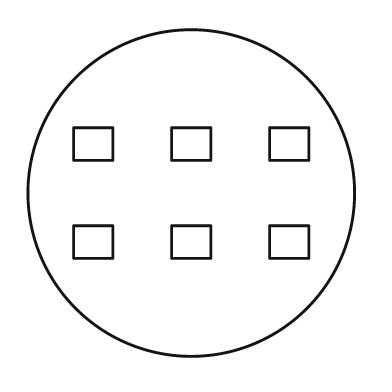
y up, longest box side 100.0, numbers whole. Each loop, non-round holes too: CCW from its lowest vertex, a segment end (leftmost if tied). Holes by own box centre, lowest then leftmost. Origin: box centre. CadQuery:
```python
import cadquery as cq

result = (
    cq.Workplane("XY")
    .moveTo(0.0, 0.0)
    .circle(50.0)
    .moveTo(-36.0, -20.0)
    .lineTo(-24.0, -20.0)
    .lineTo(-24.0, -10.0)
    .lineTo(-36.0, -10.0)
    .close()
    .moveTo(-6.0, -20.0)
    .lineTo(6.0, -20.0)
    .lineTo(6.0, -10.0)
    .lineTo(-6.0, -10.0)
    .close()
    .moveTo(24.0, -20.0)
    .lineTo(36.0, -20.0)
    .lineTo(36.0, -10.0)
    .lineTo(24.0, -10.0)
    .close()
    .moveTo(-36.0, 10.0)
    .lineTo(-24.0, 10.0)
    .lineTo(-24.0, 20.0)
    .lineTo(-36.0, 20.0)
    .close()
    .moveTo(-6.0, 10.0)
    .lineTo(6.0, 10.0)
    .lineTo(6.0, 20.0)
    .lineTo(-6.0, 20.0)
    .close()
    .moveTo(24.0, 10.0)
    .lineTo(36.0, 10.0)
    .lineTo(36.0, 20.0)
    .lineTo(24.0, 20.0)
    .close()
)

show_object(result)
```